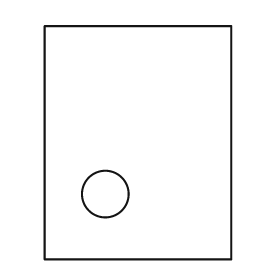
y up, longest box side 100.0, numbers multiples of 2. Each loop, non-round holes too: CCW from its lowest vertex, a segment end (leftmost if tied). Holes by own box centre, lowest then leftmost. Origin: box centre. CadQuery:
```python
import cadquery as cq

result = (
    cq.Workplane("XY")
    .moveTo(-40.0, -50.0)
    .lineTo(40.0, -50.0)
    .lineTo(40.0, 50.0)
    .lineTo(-40.0, 50.0)
    .close()
    .moveTo(-14.0, -22.0)
    .circle(10.0)
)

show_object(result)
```